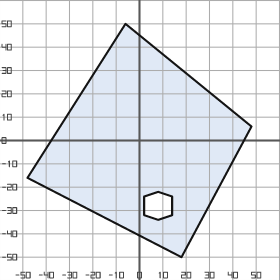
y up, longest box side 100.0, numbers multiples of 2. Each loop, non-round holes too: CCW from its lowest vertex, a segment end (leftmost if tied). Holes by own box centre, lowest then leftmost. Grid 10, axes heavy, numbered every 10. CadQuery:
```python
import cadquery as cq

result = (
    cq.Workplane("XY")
    .moveTo(18.0, -50.0)
    .lineTo(48.0, 6.0)
    .lineTo(-6.0, 50.0)
    .lineTo(-48.0, -16.0)
    .close()
    .moveTo(8.0, -34.0)
    .lineTo(14.0, -32.0)
    .lineTo(14.0, -24.0)
    .lineTo(8.0, -22.0)
    .lineTo(2.0, -24.0)
    .lineTo(2.0, -32.0)
    .close()
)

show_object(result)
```